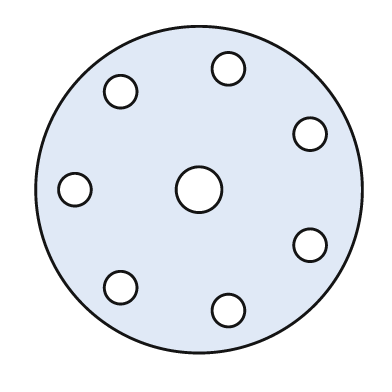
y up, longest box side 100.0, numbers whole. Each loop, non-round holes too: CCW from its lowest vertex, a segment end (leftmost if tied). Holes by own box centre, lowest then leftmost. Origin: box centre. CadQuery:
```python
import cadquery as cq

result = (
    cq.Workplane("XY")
    .moveTo(0.0, 0.0)
    .circle(50.0)
    .moveTo(9.0, -37.0)
    .circle(5.0)
    .moveTo(-24.0, -30.0)
    .circle(5.0)
    .moveTo(34.0, -17.0)
    .circle(5.0)
    .moveTo(-38.0, 0.0)
    .circle(5.0)
    .moveTo(0.0, 0.0)
    .circle(7.0)
    .moveTo(34.0, 17.0)
    .circle(5.0)
    .moveTo(-24.0, 30.0)
    .circle(5.0)
    .moveTo(9.0, 37.0)
    .circle(5.0)
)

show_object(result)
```